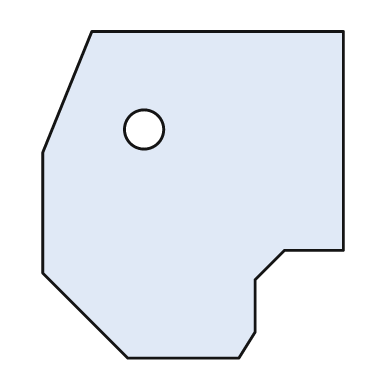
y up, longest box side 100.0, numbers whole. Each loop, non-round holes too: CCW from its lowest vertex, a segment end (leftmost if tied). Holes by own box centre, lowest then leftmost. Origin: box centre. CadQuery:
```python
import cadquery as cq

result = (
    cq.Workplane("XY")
    .moveTo(-20.0, -50.0)
    .lineTo(14.0, -50.0)
    .lineTo(19.0, -42.0)
    .lineTo(19.0, -26.0)
    .lineTo(28.0, -17.0)
    .lineTo(46.0, -17.0)
    .lineTo(46.0, 50.0)
    .lineTo(-31.0, 50.0)
    .lineTo(-46.0, 13.0)
    .lineTo(-46.0, -24.0)
    .close()
    .moveTo(-15.0, 20.0)
    .circle(6.0)
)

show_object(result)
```